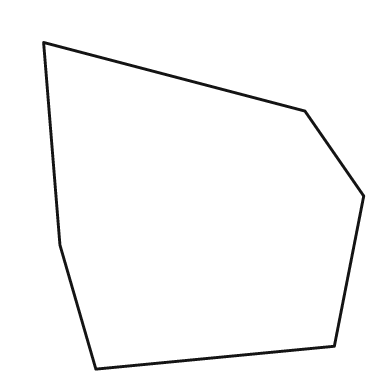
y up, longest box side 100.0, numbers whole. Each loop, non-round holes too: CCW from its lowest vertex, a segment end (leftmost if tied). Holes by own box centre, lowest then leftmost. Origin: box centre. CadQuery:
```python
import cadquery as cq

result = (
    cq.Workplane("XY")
    .moveTo(-33.0, -50.0)
    .lineTo(40.0, -43.0)
    .lineTo(49.0, 3.0)
    .lineTo(31.0, 29.0)
    .lineTo(-49.0, 50.0)
    .lineTo(-44.0, -12.0)
    .close()
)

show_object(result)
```